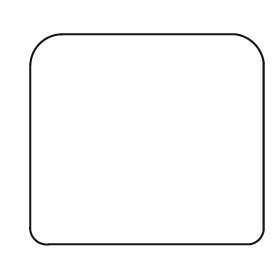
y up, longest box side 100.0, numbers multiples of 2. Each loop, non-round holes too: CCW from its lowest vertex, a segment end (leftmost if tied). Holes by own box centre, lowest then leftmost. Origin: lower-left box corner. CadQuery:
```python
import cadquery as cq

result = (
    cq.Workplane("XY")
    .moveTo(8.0, 0.0)
    .lineTo(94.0, 0.0)
    .threePointArc((98.0, 2.0), (100.0, 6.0))
    .lineTo(100.0, 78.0)
    .threePointArc((96.0, 86.0), (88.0, 90.0))
    .lineTo(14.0, 90.0)
    .threePointArc((4.0, 86.0), (0.0, 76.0))
    .lineTo(0.0, 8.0)
    .threePointArc((2.0, 2.0), (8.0, 0.0))
    .close()
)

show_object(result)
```